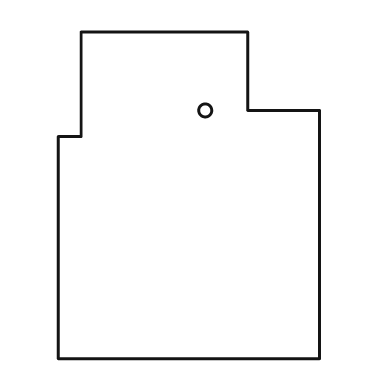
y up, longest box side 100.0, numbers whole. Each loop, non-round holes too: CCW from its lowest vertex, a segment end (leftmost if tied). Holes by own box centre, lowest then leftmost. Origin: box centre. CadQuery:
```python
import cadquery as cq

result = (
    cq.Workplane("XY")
    .moveTo(-40.0, -50.0)
    .lineTo(40.0, -50.0)
    .lineTo(40.0, 26.0)
    .lineTo(18.0, 26.0)
    .lineTo(18.0, 50.0)
    .lineTo(-33.0, 50.0)
    .lineTo(-33.0, 18.0)
    .lineTo(-40.0, 18.0)
    .close()
    .moveTo(5.0, 26.0)
    .circle(2.0)
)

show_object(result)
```